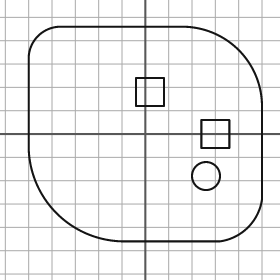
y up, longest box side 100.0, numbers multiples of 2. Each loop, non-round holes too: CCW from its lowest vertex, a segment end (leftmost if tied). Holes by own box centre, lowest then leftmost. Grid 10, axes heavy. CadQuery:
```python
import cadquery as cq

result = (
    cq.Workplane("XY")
    .moveTo(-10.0, -46.0)
    .lineTo(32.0, -46.0)
    .threePointArc((44.0, -40.0), (50.0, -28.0))
    .lineTo(50.0, 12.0)
    .threePointArc((40.0, 36.0), (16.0, 46.0))
    .lineTo(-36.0, 46.0)
    .threePointArc((-46.0, 42.0), (-50.0, 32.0))
    .lineTo(-50.0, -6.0)
    .threePointArc((-38.0, -34.0), (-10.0, -46.0))
    .close()
    .moveTo(26.0, -18.0)
    .circle(6.0)
    .moveTo(24.0, -6.0)
    .lineTo(36.0, -6.0)
    .lineTo(36.0, 6.0)
    .lineTo(24.0, 6.0)
    .close()
    .moveTo(-4.0, 12.0)
    .lineTo(8.0, 12.0)
    .lineTo(8.0, 24.0)
    .lineTo(-4.0, 24.0)
    .close()
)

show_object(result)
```